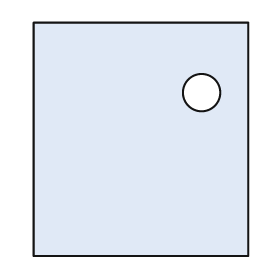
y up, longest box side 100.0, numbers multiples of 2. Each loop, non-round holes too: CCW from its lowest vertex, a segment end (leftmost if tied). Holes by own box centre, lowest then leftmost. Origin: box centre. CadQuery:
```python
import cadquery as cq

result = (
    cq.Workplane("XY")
    .moveTo(-46.0, -50.0)
    .lineTo(46.0, -50.0)
    .lineTo(46.0, 50.0)
    .lineTo(-46.0, 50.0)
    .close()
    .moveTo(26.0, 20.0)
    .circle(8.0)
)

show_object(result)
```